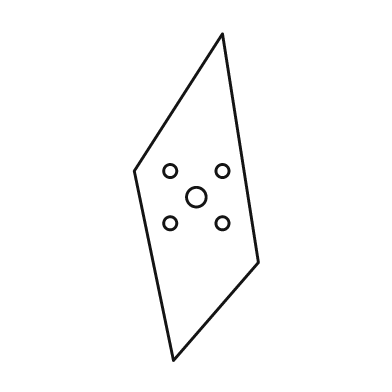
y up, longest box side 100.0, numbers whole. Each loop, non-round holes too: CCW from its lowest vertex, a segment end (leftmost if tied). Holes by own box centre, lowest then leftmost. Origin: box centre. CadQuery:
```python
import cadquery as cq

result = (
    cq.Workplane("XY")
    .moveTo(-7.0, -50.0)
    .lineTo(19.0, -20.0)
    .lineTo(8.0, 50.0)
    .lineTo(-19.0, 8.0)
    .close()
    .moveTo(-8.0, -8.0)
    .circle(2.0)
    .moveTo(8.0, -8.0)
    .circle(2.0)
    .moveTo(0.0, 0.0)
    .circle(3.0)
    .moveTo(-8.0, 8.0)
    .circle(2.0)
    .moveTo(8.0, 8.0)
    .circle(2.0)
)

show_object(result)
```